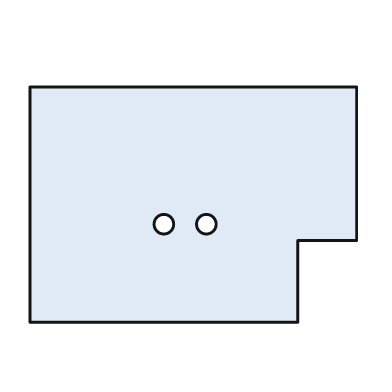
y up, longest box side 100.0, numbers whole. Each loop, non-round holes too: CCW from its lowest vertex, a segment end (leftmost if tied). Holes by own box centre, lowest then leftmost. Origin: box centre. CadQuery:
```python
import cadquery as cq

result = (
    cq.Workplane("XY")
    .moveTo(-50.0, -36.0)
    .lineTo(32.0, -36.0)
    .lineTo(32.0, -11.0)
    .lineTo(50.0, -11.0)
    .lineTo(50.0, 36.0)
    .lineTo(-50.0, 36.0)
    .close()
    .moveTo(-9.0, -6.0)
    .circle(3.0)
    .moveTo(4.0, -6.0)
    .circle(3.0)
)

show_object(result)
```